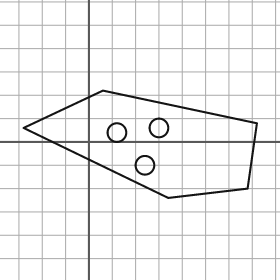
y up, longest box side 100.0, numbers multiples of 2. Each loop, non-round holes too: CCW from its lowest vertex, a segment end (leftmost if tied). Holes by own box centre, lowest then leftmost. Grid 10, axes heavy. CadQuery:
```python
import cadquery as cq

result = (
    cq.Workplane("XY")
    .moveTo(34.0, -24.0)
    .lineTo(68.0, -20.0)
    .lineTo(72.0, 8.0)
    .lineTo(6.0, 22.0)
    .lineTo(-28.0, 6.0)
    .close()
    .moveTo(24.0, -10.0)
    .circle(4.0)
    .moveTo(12.0, 4.0)
    .circle(4.0)
    .moveTo(30.0, 6.0)
    .circle(4.0)
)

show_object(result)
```